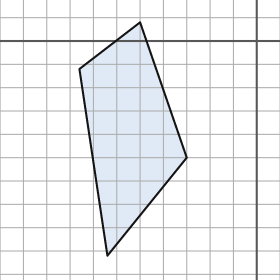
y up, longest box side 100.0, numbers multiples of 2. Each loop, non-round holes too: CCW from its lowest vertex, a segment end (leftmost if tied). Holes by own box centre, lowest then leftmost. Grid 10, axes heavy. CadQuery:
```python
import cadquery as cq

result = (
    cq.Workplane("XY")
    .moveTo(-64.0, -92.0)
    .lineTo(-30.0, -50.0)
    .lineTo(-50.0, 8.0)
    .lineTo(-76.0, -12.0)
    .close()
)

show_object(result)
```